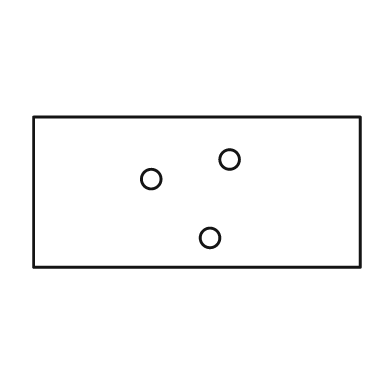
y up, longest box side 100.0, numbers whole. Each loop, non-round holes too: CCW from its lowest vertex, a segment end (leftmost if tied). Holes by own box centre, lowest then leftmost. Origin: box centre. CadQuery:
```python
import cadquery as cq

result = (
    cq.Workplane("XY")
    .moveTo(-50.0, -23.0)
    .lineTo(50.0, -23.0)
    .lineTo(50.0, 23.0)
    .lineTo(-50.0, 23.0)
    .close()
    .moveTo(4.0, -14.0)
    .circle(3.0)
    .moveTo(-14.0, 4.0)
    .circle(3.0)
    .moveTo(10.0, 10.0)
    .circle(3.0)
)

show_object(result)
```